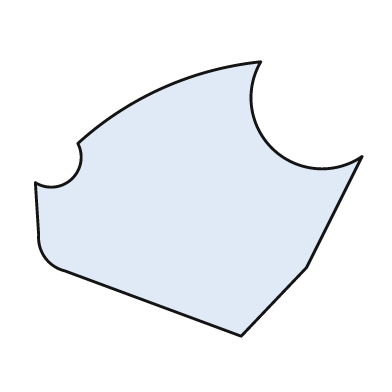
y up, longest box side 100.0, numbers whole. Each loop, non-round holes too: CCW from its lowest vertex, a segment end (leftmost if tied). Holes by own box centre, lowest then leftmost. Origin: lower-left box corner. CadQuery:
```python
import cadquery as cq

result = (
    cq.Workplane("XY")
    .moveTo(63.0, 0.0)
    .lineTo(83.0, 21.0)
    .lineTo(100.0, 55.0)
    .threePointArc((73.0, 57.0), (69.0, 84.0))
    .threePointArc((39.0, 76.0), (13.0, 59.0))
    .threePointArc((11.0, 48.0), (0.0, 47.0))
    .lineTo(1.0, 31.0)
    .threePointArc((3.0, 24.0), (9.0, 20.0))
    .close()
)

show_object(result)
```